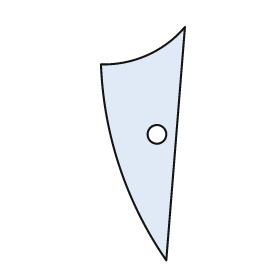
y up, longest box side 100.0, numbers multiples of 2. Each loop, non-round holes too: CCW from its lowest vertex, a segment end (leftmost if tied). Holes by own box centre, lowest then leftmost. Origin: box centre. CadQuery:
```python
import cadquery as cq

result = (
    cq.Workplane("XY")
    .moveTo(10.0, -50.0)
    .lineTo(18.0, 50.0)
    .threePointArc((2.0, 38.0), (-18.0, 34.0))
    .threePointArc((-10.0, -10.0), (10.0, -50.0))
    .close()
    .moveTo(6.0, 4.0)
    .circle(4.0)
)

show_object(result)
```